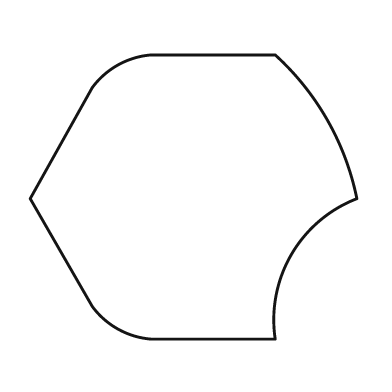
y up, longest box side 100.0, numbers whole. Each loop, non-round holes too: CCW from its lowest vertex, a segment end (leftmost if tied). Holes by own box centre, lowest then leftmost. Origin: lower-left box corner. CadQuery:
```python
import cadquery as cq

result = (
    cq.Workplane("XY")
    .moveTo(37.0, 0.0)
    .lineTo(75.0, 0.0)
    .threePointArc((80.0, 26.0), (100.0, 43.0))
    .threePointArc((91.0, 67.0), (75.0, 87.0))
    .lineTo(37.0, 87.0)
    .threePointArc((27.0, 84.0), (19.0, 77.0))
    .lineTo(0.0, 43.0)
    .lineTo(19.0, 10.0)
    .threePointArc((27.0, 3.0), (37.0, 0.0))
    .close()
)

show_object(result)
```